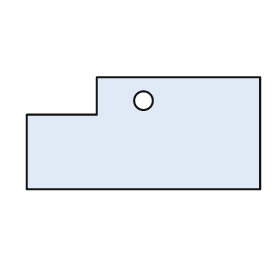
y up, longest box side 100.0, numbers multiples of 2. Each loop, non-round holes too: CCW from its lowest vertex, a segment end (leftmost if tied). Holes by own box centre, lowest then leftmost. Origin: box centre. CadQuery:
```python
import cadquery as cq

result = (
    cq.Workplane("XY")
    .moveTo(-50.0, -24.0)
    .lineTo(50.0, -24.0)
    .lineTo(50.0, 24.0)
    .lineTo(-20.0, 24.0)
    .lineTo(-20.0, 8.0)
    .lineTo(-50.0, 8.0)
    .close()
    .moveTo(0.0, 14.0)
    .circle(4.0)
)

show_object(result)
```